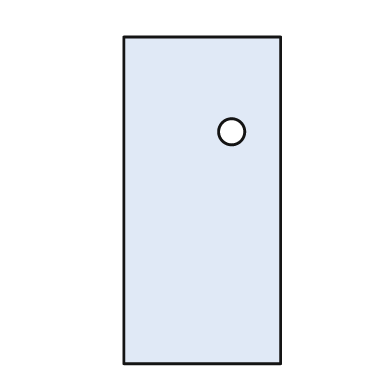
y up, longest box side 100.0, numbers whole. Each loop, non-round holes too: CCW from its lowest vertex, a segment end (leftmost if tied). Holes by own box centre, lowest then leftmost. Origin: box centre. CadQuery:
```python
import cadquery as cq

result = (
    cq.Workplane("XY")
    .moveTo(-24.0, -50.0)
    .lineTo(24.0, -50.0)
    .lineTo(24.0, 50.0)
    .lineTo(-24.0, 50.0)
    .close()
    .moveTo(9.0, 21.0)
    .circle(4.0)
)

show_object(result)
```